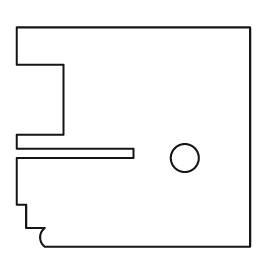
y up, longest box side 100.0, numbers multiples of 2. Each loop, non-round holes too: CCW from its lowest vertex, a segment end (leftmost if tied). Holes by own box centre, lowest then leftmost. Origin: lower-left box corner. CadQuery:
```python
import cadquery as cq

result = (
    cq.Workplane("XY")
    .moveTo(12.0, 0.0)
    .lineTo(100.0, 0.0)
    .lineTo(100.0, 94.0)
    .lineTo(0.0, 94.0)
    .lineTo(0.0, 78.0)
    .lineTo(20.0, 78.0)
    .lineTo(20.0, 48.0)
    .lineTo(0.0, 48.0)
    .lineTo(0.0, 42.0)
    .lineTo(50.0, 42.0)
    .lineTo(50.0, 38.0)
    .lineTo(0.0, 38.0)
    .lineTo(0.0, 18.0)
    .lineTo(4.0, 18.0)
    .lineTo(4.0, 8.0)
    .lineTo(12.0, 8.0)
    .threePointArc((10.0, 4.0), (12.0, 0.0))
    .close()
    .moveTo(72.0, 38.0)
    .circle(6.0)
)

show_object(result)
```